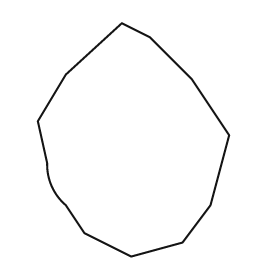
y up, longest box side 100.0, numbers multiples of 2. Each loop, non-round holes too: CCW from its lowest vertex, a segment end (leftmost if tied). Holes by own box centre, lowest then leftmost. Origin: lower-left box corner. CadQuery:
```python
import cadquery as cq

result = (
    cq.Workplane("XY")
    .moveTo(40.0, 0.0)
    .lineTo(62.0, 6.0)
    .lineTo(74.0, 22.0)
    .lineTo(82.0, 52.0)
    .lineTo(66.0, 76.0)
    .lineTo(48.0, 94.0)
    .lineTo(36.0, 100.0)
    .lineTo(12.0, 78.0)
    .lineTo(0.0, 58.0)
    .lineTo(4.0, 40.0)
    .threePointArc((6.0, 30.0), (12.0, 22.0))
    .lineTo(20.0, 10.0)
    .close()
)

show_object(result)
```